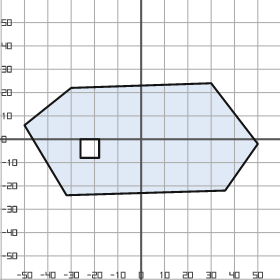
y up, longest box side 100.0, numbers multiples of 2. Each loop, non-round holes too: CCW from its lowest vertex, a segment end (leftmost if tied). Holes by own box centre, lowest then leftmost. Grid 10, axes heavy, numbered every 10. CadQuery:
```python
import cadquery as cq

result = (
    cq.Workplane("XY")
    .moveTo(-32.0, -24.0)
    .lineTo(36.0, -22.0)
    .lineTo(50.0, -2.0)
    .lineTo(30.0, 24.0)
    .lineTo(-30.0, 22.0)
    .lineTo(-50.0, 6.0)
    .close()
    .moveTo(-26.0, -8.0)
    .lineTo(-18.0, -8.0)
    .lineTo(-18.0, 0.0)
    .lineTo(-26.0, 0.0)
    .close()
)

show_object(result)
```